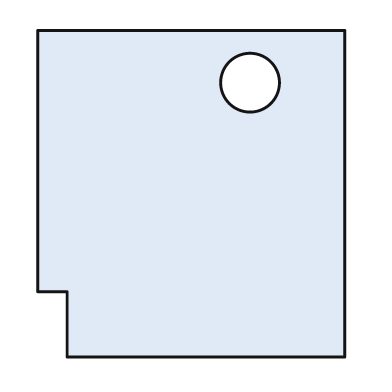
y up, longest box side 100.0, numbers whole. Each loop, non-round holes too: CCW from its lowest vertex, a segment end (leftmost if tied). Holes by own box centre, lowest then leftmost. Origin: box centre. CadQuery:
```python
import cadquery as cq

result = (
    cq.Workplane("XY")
    .moveTo(-38.0, -50.0)
    .lineTo(47.0, -50.0)
    .lineTo(47.0, 50.0)
    .lineTo(-47.0, 50.0)
    .lineTo(-47.0, -30.0)
    .lineTo(-38.0, -30.0)
    .close()
    .moveTo(18.0, 34.0)
    .circle(9.0)
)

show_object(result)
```